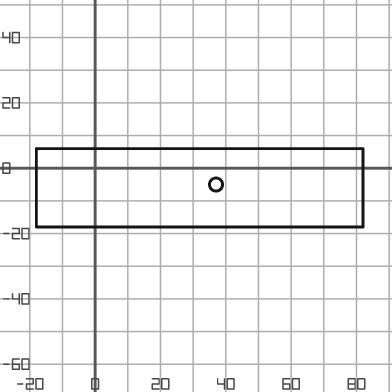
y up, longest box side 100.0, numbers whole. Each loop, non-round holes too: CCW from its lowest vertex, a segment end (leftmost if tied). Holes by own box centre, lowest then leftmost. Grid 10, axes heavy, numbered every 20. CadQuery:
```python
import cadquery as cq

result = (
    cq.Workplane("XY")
    .moveTo(-18.0, -18.0)
    .lineTo(82.0, -18.0)
    .lineTo(82.0, 6.0)
    .lineTo(-18.0, 6.0)
    .close()
    .moveTo(37.0, -5.0)
    .circle(2.0)
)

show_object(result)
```